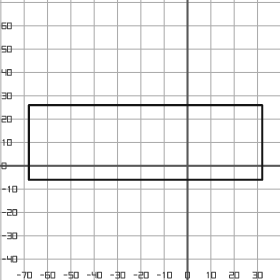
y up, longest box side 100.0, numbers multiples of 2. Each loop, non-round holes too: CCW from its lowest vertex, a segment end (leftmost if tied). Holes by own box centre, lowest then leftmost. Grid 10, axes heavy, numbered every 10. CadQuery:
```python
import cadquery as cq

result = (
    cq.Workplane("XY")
    .moveTo(-68.0, -6.0)
    .lineTo(32.0, -6.0)
    .lineTo(32.0, 26.0)
    .lineTo(-68.0, 26.0)
    .close()
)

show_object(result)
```